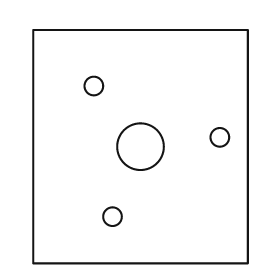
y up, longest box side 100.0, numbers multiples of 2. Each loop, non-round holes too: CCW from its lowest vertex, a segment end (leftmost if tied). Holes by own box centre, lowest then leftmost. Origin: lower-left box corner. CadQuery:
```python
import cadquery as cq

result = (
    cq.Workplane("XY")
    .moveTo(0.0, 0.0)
    .lineTo(92.0, 0.0)
    .lineTo(92.0, 100.0)
    .lineTo(0.0, 100.0)
    .close()
    .moveTo(34.0, 20.0)
    .circle(4.0)
    .moveTo(46.0, 50.0)
    .circle(10.0)
    .moveTo(80.0, 54.0)
    .circle(4.0)
    .moveTo(26.0, 76.0)
    .circle(4.0)
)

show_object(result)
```